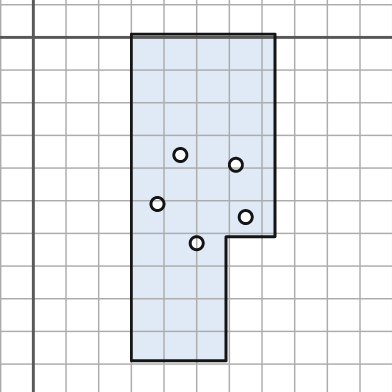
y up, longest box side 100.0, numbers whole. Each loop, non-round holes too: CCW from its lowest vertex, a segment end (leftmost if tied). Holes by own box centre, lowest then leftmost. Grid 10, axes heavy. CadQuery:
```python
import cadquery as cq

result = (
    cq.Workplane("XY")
    .moveTo(30.0, -99.0)
    .lineTo(59.0, -99.0)
    .lineTo(59.0, -61.0)
    .lineTo(74.0, -61.0)
    .lineTo(74.0, 1.0)
    .lineTo(30.0, 1.0)
    .close()
    .moveTo(50.0, -63.0)
    .circle(2.0)
    .moveTo(65.0, -55.0)
    .circle(2.0)
    .moveTo(38.0, -51.0)
    .circle(2.0)
    .moveTo(62.0, -39.0)
    .circle(2.0)
    .moveTo(45.0, -36.0)
    .circle(2.0)
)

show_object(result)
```